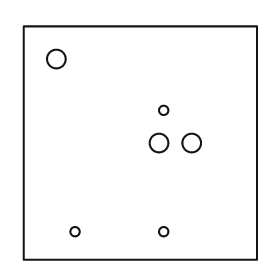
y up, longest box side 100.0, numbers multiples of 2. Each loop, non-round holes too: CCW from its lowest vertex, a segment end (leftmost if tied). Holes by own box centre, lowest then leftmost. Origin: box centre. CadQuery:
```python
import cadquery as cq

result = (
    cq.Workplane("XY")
    .moveTo(-50.0, -50.0)
    .lineTo(50.0, -50.0)
    .lineTo(50.0, 50.0)
    .lineTo(-50.0, 50.0)
    .close()
    .moveTo(-28.0, -38.0)
    .circle(2.0)
    .moveTo(10.0, -38.0)
    .circle(2.0)
    .moveTo(8.0, 0.0)
    .circle(4.0)
    .moveTo(22.0, 0.0)
    .circle(4.0)
    .moveTo(10.0, 14.0)
    .circle(2.0)
    .moveTo(-36.0, 36.0)
    .circle(4.0)
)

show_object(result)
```